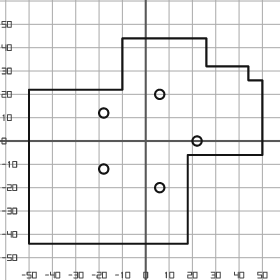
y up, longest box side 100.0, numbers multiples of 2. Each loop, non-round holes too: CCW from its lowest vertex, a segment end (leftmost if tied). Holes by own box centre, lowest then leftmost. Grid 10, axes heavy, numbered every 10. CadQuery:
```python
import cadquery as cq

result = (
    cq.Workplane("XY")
    .moveTo(-50.0, -44.0)
    .lineTo(18.0, -44.0)
    .lineTo(18.0, -6.0)
    .lineTo(50.0, -6.0)
    .lineTo(50.0, 26.0)
    .lineTo(44.0, 26.0)
    .lineTo(44.0, 32.0)
    .lineTo(26.0, 32.0)
    .lineTo(26.0, 44.0)
    .lineTo(-10.0, 44.0)
    .lineTo(-10.0, 22.0)
    .lineTo(-50.0, 22.0)
    .close()
    .moveTo(6.0, -20.0)
    .circle(2.0)
    .moveTo(-18.0, -12.0)
    .circle(2.0)
    .moveTo(22.0, 0.0)
    .circle(2.0)
    .moveTo(-18.0, 12.0)
    .circle(2.0)
    .moveTo(6.0, 20.0)
    .circle(2.0)
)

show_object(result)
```